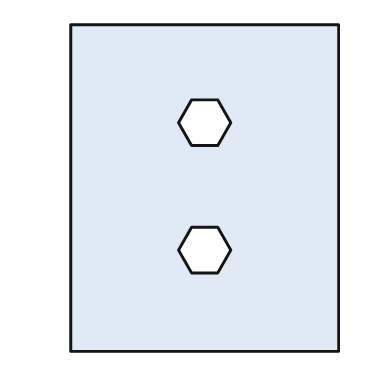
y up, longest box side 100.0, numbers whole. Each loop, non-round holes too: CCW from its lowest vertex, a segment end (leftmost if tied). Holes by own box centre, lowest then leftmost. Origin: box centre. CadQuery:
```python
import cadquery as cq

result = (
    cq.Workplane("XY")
    .moveTo(-41.0, -50.0)
    .lineTo(41.0, -50.0)
    .lineTo(41.0, 50.0)
    .lineTo(-41.0, 50.0)
    .close()
    .moveTo(-4.0, -26.0)
    .lineTo(4.0, -26.0)
    .lineTo(8.0, -19.0)
    .lineTo(4.0, -12.0)
    .lineTo(-4.0, -12.0)
    .lineTo(-8.0, -19.0)
    .close()
    .moveTo(-4.0, 13.0)
    .lineTo(4.0, 13.0)
    .lineTo(8.0, 20.0)
    .lineTo(4.0, 27.0)
    .lineTo(-4.0, 27.0)
    .lineTo(-8.0, 20.0)
    .close()
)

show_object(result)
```